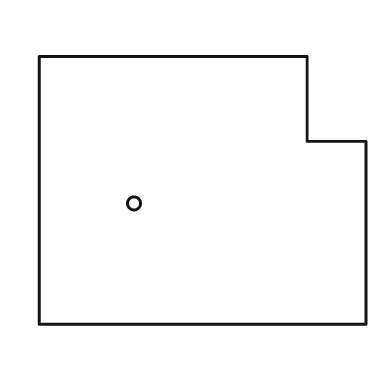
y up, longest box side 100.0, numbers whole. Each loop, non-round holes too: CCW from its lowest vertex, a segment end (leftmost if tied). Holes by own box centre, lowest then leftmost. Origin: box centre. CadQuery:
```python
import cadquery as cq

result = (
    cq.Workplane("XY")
    .moveTo(-50.0, -41.0)
    .lineTo(50.0, -41.0)
    .lineTo(50.0, 15.0)
    .lineTo(32.0, 15.0)
    .lineTo(32.0, 41.0)
    .lineTo(-50.0, 41.0)
    .close()
    .moveTo(-21.0, -4.0)
    .circle(2.0)
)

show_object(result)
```